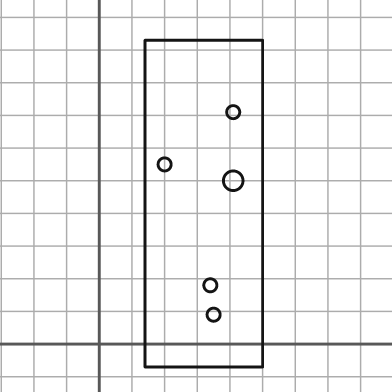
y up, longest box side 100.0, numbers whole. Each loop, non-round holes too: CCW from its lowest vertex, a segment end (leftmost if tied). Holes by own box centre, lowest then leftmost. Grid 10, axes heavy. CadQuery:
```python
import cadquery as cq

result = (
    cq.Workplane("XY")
    .moveTo(14.0, -7.0)
    .lineTo(50.0, -7.0)
    .lineTo(50.0, 93.0)
    .lineTo(14.0, 93.0)
    .close()
    .moveTo(35.0, 9.0)
    .circle(2.0)
    .moveTo(34.0, 18.0)
    .circle(2.0)
    .moveTo(41.0, 50.0)
    .circle(3.0)
    .moveTo(20.0, 55.0)
    .circle(2.0)
    .moveTo(41.0, 71.0)
    .circle(2.0)
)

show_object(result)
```